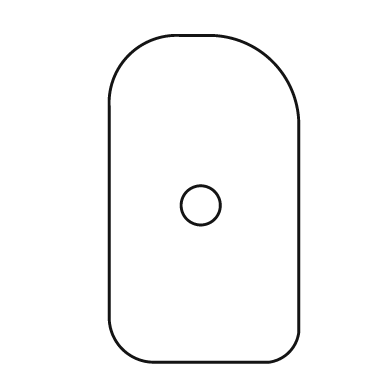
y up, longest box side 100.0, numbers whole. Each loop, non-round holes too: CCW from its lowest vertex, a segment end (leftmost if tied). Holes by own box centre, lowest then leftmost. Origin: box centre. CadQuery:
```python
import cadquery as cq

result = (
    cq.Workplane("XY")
    .moveTo(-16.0, -50.0)
    .lineTo(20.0, -50.0)
    .threePointArc((26.0, -47.0), (29.0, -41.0))
    .lineTo(29.0, 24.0)
    .threePointArc((21.0, 42.0), (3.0, 50.0))
    .lineTo(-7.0, 50.0)
    .threePointArc((-23.0, 44.0), (-29.0, 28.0))
    .lineTo(-29.0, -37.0)
    .threePointArc((-25.0, -46.0), (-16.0, -50.0))
    .close()
    .moveTo(-1.0, -2.0)
    .circle(6.0)
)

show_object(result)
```